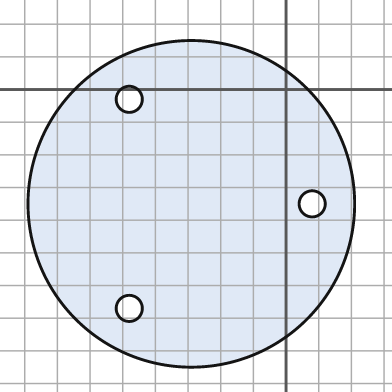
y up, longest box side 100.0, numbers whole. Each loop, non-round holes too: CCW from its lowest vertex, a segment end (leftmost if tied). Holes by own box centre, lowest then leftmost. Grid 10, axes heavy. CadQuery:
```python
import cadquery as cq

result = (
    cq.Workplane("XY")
    .moveTo(-29.0, -35.0)
    .circle(50.0)
    .moveTo(-48.0, -67.0)
    .circle(4.0)
    .moveTo(8.0, -35.0)
    .circle(4.0)
    .moveTo(-48.0, -3.0)
    .circle(4.0)
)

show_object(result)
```